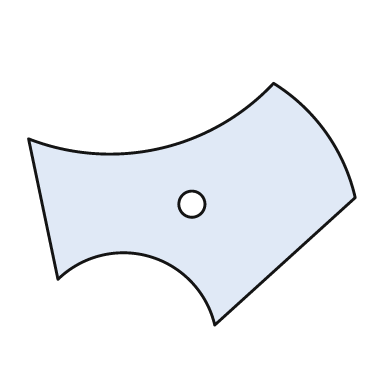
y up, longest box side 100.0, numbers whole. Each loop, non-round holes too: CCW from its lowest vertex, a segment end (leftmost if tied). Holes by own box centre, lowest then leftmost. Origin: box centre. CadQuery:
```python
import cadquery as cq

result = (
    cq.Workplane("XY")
    .moveTo(7.0, -37.0)
    .lineTo(50.0, 2.0)
    .threePointArc((41.0, 22.0), (25.0, 37.0))
    .threePointArc((-10.0, 17.0), (-50.0, 20.0))
    .lineTo(-41.0, -23.0)
    .threePointArc((-13.0, -16.0), (7.0, -37.0))
    .close()
    .moveTo(0.0, 0.0)
    .circle(4.0)
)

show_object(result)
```